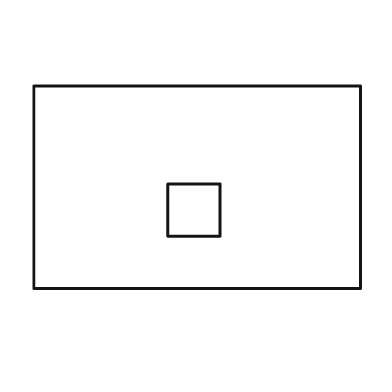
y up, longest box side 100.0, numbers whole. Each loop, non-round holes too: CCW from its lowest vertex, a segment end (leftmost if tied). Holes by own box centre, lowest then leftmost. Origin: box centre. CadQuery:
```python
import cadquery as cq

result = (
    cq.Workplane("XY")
    .moveTo(-50.0, -31.0)
    .lineTo(50.0, -31.0)
    .lineTo(50.0, 31.0)
    .lineTo(-50.0, 31.0)
    .close()
    .moveTo(-9.0, -15.0)
    .lineTo(7.0, -15.0)
    .lineTo(7.0, 1.0)
    .lineTo(-9.0, 1.0)
    .close()
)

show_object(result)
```